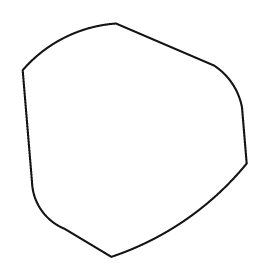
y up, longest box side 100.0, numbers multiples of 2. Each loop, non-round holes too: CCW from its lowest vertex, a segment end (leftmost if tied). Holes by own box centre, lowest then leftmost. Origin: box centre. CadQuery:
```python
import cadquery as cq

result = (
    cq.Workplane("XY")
    .moveTo(-10.0, -50.0)
    .threePointArc((22.0, -34.0), (48.0, -10.0))
    .lineTo(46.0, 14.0)
    .threePointArc((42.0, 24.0), (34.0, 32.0))
    .lineTo(-8.0, 50.0)
    .threePointArc((-30.0, 44.0), (-48.0, 30.0))
    .lineTo(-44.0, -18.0)
    .threePointArc((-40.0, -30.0), (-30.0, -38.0))
    .close()
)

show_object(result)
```